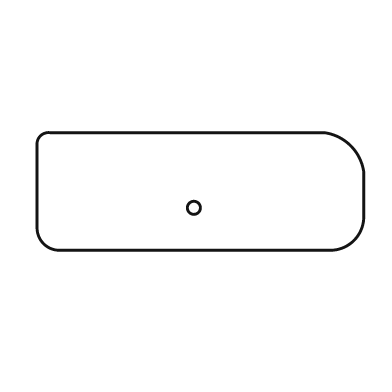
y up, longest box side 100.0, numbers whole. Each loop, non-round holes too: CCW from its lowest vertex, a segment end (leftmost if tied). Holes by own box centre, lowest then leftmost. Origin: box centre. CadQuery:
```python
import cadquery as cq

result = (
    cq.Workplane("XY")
    .moveTo(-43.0, -18.0)
    .lineTo(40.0, -18.0)
    .threePointArc((47.0, -15.0), (50.0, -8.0))
    .lineTo(50.0, 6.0)
    .threePointArc((46.0, 14.0), (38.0, 18.0))
    .lineTo(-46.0, 18.0)
    .threePointArc((-49.0, 17.0), (-50.0, 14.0))
    .lineTo(-50.0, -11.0)
    .threePointArc((-48.0, -16.0), (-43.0, -18.0))
    .close()
    .moveTo(-2.0, -5.0)
    .circle(2.0)
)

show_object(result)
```